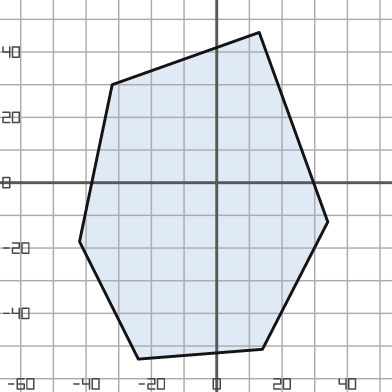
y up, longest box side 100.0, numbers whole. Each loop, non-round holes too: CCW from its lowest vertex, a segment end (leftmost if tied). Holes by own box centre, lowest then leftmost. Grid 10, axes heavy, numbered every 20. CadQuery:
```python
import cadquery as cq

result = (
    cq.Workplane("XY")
    .moveTo(-24.0, -54.0)
    .lineTo(14.0, -51.0)
    .lineTo(34.0, -12.0)
    .lineTo(13.0, 46.0)
    .lineTo(-32.0, 30.0)
    .lineTo(-42.0, -18.0)
    .close()
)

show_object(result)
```